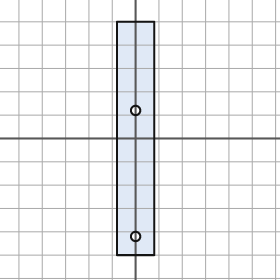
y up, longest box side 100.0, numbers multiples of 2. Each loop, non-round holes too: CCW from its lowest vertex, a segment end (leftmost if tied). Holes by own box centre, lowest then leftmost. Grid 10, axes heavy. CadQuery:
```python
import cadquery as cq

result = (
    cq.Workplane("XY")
    .moveTo(-8.0, -50.0)
    .lineTo(8.0, -50.0)
    .lineTo(8.0, 50.0)
    .lineTo(-8.0, 50.0)
    .close()
    .moveTo(0.0, -42.0)
    .circle(2.0)
    .moveTo(0.0, 12.0)
    .circle(2.0)
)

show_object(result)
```